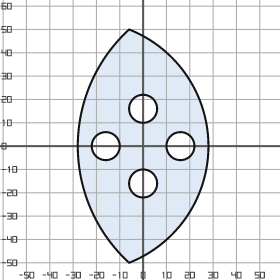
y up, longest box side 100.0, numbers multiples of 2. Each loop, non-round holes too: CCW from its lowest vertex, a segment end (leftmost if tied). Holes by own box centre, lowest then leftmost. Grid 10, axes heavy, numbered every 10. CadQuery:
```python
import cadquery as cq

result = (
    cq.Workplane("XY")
    .moveTo(-6.0, -50.0)
    .threePointArc((28.0, 0.0), (-6.0, 50.0))
    .threePointArc((-28.0, 0.0), (-6.0, -50.0))
    .close()
    .moveTo(0.0, -16.0)
    .circle(6.0)
    .moveTo(-16.0, 0.0)
    .circle(6.0)
    .moveTo(16.0, 0.0)
    .circle(6.0)
    .moveTo(0.0, 16.0)
    .circle(6.0)
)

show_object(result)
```